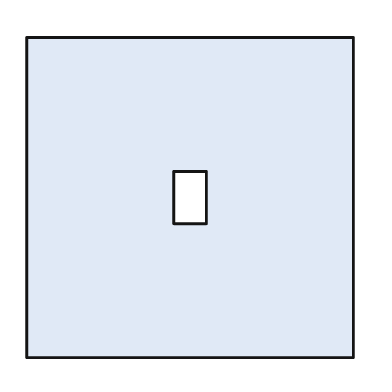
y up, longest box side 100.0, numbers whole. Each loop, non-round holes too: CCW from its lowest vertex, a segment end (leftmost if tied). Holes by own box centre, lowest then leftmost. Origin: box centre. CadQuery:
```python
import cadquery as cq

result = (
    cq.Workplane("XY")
    .moveTo(-50.0, -49.0)
    .lineTo(50.0, -49.0)
    .lineTo(50.0, 49.0)
    .lineTo(-50.0, 49.0)
    .close()
    .moveTo(-5.0, -8.0)
    .lineTo(5.0, -8.0)
    .lineTo(5.0, 8.0)
    .lineTo(-5.0, 8.0)
    .close()
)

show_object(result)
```